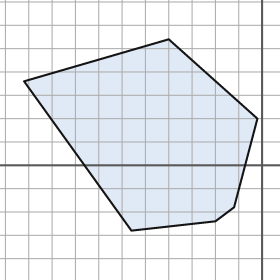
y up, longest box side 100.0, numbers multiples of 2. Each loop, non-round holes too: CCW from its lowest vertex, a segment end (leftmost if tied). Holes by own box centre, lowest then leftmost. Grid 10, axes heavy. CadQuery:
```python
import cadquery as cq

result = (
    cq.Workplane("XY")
    .moveTo(-56.0, -28.0)
    .lineTo(-20.0, -24.0)
    .lineTo(-12.0, -18.0)
    .lineTo(-2.0, 20.0)
    .lineTo(-40.0, 54.0)
    .lineTo(-102.0, 36.0)
    .close()
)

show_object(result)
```